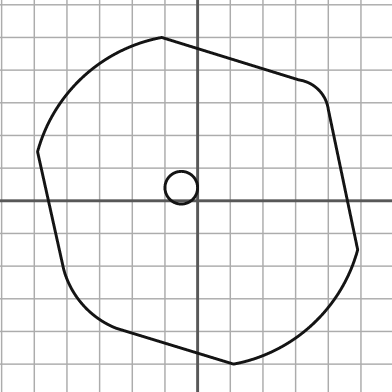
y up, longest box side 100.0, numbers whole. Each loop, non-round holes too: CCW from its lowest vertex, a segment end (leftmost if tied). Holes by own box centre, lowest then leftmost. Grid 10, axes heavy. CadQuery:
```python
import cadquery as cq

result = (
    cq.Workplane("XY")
    .moveTo(11.0, -50.0)
    .threePointArc((35.0, -38.0), (49.0, -15.0))
    .lineTo(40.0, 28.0)
    .threePointArc((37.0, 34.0), (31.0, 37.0))
    .lineTo(-11.0, 50.0)
    .threePointArc((-35.0, 38.0), (-49.0, 15.0))
    .lineTo(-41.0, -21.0)
    .threePointArc((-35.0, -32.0), (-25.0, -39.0))
    .close()
    .moveTo(-5.0, 4.0)
    .circle(5.0)
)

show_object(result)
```